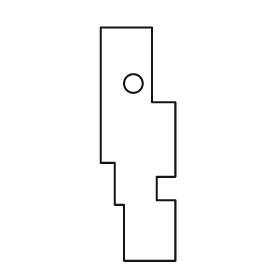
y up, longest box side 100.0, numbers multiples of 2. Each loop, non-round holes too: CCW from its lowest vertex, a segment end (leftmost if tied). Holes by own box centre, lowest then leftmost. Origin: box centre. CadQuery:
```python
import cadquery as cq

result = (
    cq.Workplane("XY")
    .moveTo(-6.0, -50.0)
    .lineTo(16.0, -50.0)
    .lineTo(16.0, -24.0)
    .lineTo(8.0, -24.0)
    .lineTo(8.0, -14.0)
    .lineTo(16.0, -14.0)
    .lineTo(16.0, 18.0)
    .lineTo(6.0, 18.0)
    .lineTo(6.0, 50.0)
    .lineTo(-16.0, 50.0)
    .lineTo(-16.0, -8.0)
    .lineTo(-10.0, -8.0)
    .lineTo(-10.0, -26.0)
    .lineTo(-6.0, -26.0)
    .close()
    .moveTo(-2.0, 26.0)
    .circle(4.0)
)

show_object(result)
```